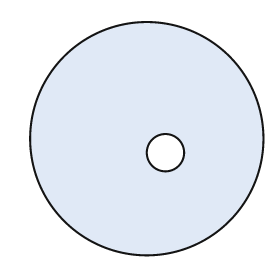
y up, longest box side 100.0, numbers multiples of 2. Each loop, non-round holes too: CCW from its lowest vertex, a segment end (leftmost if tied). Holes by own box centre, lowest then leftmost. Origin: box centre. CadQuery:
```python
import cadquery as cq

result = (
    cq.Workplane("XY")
    .moveTo(0.0, 0.0)
    .circle(50.0)
    .moveTo(8.0, -6.0)
    .circle(8.0)
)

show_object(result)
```